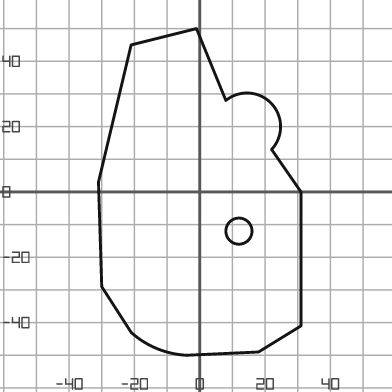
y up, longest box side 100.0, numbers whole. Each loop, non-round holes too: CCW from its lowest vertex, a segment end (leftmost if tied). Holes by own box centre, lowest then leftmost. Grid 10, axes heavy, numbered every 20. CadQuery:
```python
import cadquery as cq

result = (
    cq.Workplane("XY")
    .moveTo(-4.0, -50.0)
    .lineTo(18.0, -49.0)
    .lineTo(31.0, -41.0)
    .lineTo(31.0, 0.0)
    .lineTo(22.0, 13.0)
    .threePointArc((22.0, 27.0), (8.0, 28.0))
    .lineTo(-1.0, 50.0)
    .lineTo(-21.0, 45.0)
    .lineTo(-31.0, 3.0)
    .lineTo(-30.0, -29.0)
    .lineTo(-21.0, -43.0)
    .threePointArc((-13.0, -48.0), (-4.0, -50.0))
    .close()
    .moveTo(12.0, -12.0)
    .circle(4.0)
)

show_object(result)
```